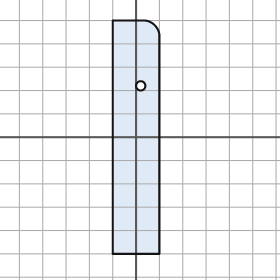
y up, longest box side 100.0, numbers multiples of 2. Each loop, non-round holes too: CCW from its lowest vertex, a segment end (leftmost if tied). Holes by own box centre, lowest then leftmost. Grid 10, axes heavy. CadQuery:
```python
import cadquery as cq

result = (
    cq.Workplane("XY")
    .moveTo(-10.0, -50.0)
    .lineTo(10.0, -50.0)
    .lineTo(10.0, 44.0)
    .threePointArc((8.0, 48.0), (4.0, 50.0))
    .lineTo(-10.0, 50.0)
    .close()
    .moveTo(2.0, 22.0)
    .circle(2.0)
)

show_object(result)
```